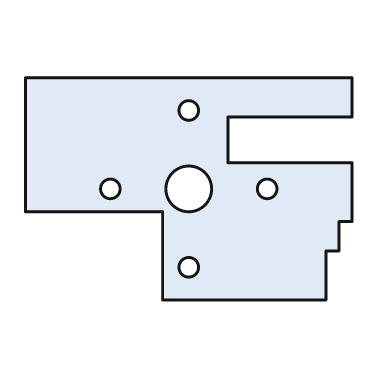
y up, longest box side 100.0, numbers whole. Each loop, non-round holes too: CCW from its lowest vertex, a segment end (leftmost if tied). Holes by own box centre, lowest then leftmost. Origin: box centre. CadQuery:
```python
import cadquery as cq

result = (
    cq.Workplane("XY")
    .moveTo(-8.0, -34.0)
    .lineTo(42.0, -34.0)
    .lineTo(42.0, -19.0)
    .lineTo(46.0, -19.0)
    .lineTo(46.0, -10.0)
    .lineTo(50.0, -10.0)
    .lineTo(50.0, 8.0)
    .lineTo(12.0, 8.0)
    .lineTo(12.0, 22.0)
    .lineTo(50.0, 22.0)
    .lineTo(50.0, 34.0)
    .lineTo(-50.0, 34.0)
    .lineTo(-50.0, -7.0)
    .lineTo(-8.0, -7.0)
    .close()
    .moveTo(0.0, -24.0)
    .circle(3.0)
    .moveTo(-24.0, 0.0)
    .circle(3.0)
    .moveTo(0.0, 0.0)
    .circle(7.0)
    .moveTo(24.0, 0.0)
    .circle(3.0)
    .moveTo(0.0, 24.0)
    .circle(3.0)
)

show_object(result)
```